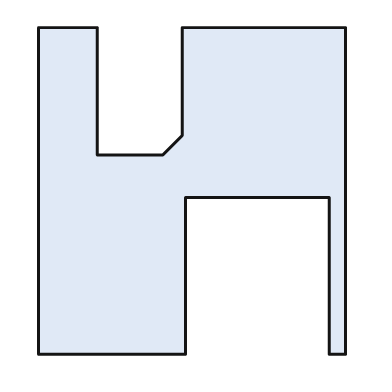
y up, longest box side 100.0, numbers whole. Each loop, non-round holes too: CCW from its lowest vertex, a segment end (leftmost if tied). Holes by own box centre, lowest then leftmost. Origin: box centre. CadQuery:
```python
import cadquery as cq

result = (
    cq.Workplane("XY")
    .moveTo(-47.0, -50.0)
    .lineTo(-2.0, -50.0)
    .lineTo(-2.0, -2.0)
    .lineTo(42.0, -2.0)
    .lineTo(42.0, -50.0)
    .lineTo(47.0, -50.0)
    .lineTo(47.0, 50.0)
    .lineTo(-3.0, 50.0)
    .lineTo(-3.0, 17.0)
    .lineTo(-9.0, 11.0)
    .lineTo(-29.0, 11.0)
    .lineTo(-29.0, 50.0)
    .lineTo(-47.0, 50.0)
    .close()
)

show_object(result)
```